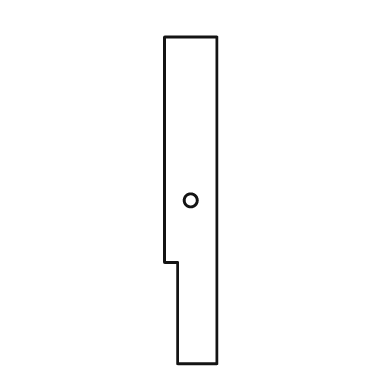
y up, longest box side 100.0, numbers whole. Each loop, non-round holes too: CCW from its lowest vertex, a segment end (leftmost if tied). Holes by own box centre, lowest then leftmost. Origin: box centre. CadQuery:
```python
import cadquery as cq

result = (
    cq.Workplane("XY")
    .moveTo(-4.0, -50.0)
    .lineTo(8.0, -50.0)
    .lineTo(8.0, 50.0)
    .lineTo(-8.0, 50.0)
    .lineTo(-8.0, -19.0)
    .lineTo(-4.0, -19.0)
    .close()
    .moveTo(0.0, 0.0)
    .circle(2.0)
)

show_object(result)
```